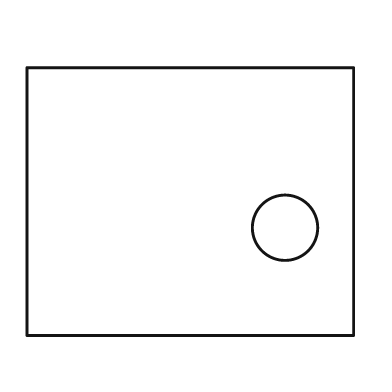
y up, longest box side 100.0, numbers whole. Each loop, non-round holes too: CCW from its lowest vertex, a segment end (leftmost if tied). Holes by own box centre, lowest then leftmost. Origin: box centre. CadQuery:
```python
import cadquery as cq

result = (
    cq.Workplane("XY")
    .moveTo(-50.0, -41.0)
    .lineTo(50.0, -41.0)
    .lineTo(50.0, 41.0)
    .lineTo(-50.0, 41.0)
    .close()
    .moveTo(29.0, -8.0)
    .circle(10.0)
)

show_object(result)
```